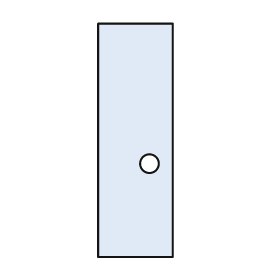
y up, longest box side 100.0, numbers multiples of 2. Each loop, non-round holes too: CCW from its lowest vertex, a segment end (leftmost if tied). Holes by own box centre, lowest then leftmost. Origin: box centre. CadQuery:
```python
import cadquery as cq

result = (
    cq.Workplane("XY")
    .moveTo(-16.0, -50.0)
    .lineTo(16.0, -50.0)
    .lineTo(16.0, 50.0)
    .lineTo(-16.0, 50.0)
    .close()
    .moveTo(6.0, -10.0)
    .circle(4.0)
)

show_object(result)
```